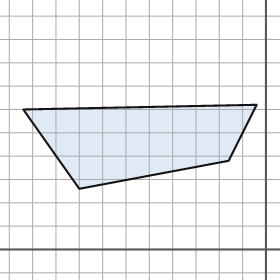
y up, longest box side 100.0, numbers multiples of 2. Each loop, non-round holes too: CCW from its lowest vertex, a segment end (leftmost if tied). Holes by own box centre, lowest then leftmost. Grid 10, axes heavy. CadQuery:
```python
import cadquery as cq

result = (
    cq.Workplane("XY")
    .moveTo(-80.0, 26.0)
    .lineTo(-16.0, 38.0)
    .lineTo(-4.0, 62.0)
    .lineTo(-104.0, 60.0)
    .close()
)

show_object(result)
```